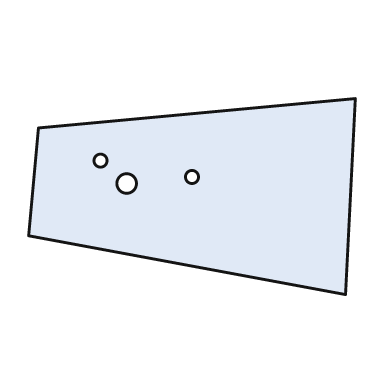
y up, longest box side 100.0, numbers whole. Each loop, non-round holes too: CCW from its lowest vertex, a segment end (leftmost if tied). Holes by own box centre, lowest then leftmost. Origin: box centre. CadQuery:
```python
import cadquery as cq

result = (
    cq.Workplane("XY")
    .moveTo(47.0, -30.0)
    .lineTo(50.0, 30.0)
    .lineTo(-47.0, 21.0)
    .lineTo(-50.0, -12.0)
    .close()
    .moveTo(-20.0, 4.0)
    .circle(3.0)
    .moveTo(0.0, 6.0)
    .circle(2.0)
    .moveTo(-28.0, 11.0)
    .circle(2.0)
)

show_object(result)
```